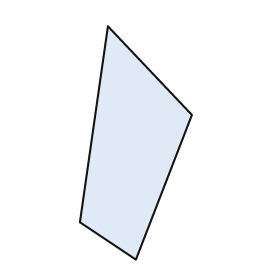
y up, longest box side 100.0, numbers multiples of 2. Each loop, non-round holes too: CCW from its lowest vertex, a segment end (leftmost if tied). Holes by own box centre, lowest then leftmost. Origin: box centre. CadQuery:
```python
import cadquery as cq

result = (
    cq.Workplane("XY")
    .moveTo(0.0, -50.0)
    .lineTo(24.0, 12.0)
    .lineTo(-12.0, 50.0)
    .lineTo(-24.0, -34.0)
    .close()
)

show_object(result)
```